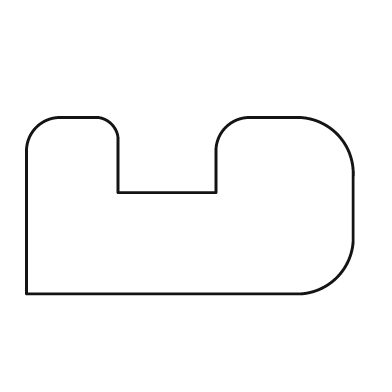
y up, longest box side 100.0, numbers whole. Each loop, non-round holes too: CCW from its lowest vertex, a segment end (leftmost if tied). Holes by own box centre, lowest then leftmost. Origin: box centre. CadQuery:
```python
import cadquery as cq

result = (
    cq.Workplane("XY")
    .moveTo(-50.0, -27.0)
    .lineTo(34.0, -27.0)
    .threePointArc((45.0, -22.0), (50.0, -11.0))
    .lineTo(50.0, 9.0)
    .threePointArc((45.0, 22.0), (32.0, 27.0))
    .lineTo(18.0, 27.0)
    .threePointArc((11.0, 24.0), (8.0, 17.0))
    .lineTo(8.0, 4.0)
    .lineTo(-22.0, 4.0)
    .lineTo(-22.0, 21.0)
    .threePointArc((-24.0, 25.0), (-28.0, 27.0))
    .lineTo(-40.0, 27.0)
    .threePointArc((-47.0, 24.0), (-50.0, 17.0))
    .close()
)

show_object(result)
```